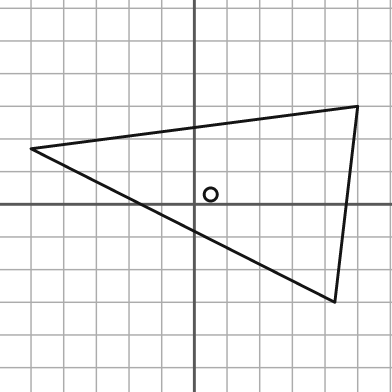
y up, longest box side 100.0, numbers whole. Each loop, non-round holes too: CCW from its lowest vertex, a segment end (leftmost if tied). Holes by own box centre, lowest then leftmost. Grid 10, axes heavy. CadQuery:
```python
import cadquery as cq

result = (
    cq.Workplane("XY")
    .moveTo(43.0, -30.0)
    .lineTo(50.0, 30.0)
    .lineTo(-50.0, 17.0)
    .close()
    .moveTo(5.0, 3.0)
    .circle(2.0)
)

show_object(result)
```